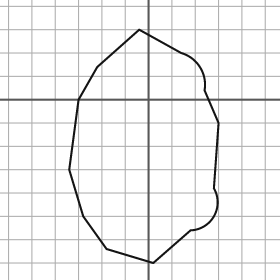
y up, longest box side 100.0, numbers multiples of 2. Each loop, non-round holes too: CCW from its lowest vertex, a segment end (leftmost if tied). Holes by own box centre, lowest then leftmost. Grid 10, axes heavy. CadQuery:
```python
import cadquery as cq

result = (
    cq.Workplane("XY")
    .moveTo(2.0, -70.0)
    .lineTo(18.0, -56.0)
    .threePointArc((28.0, -50.0), (28.0, -38.0))
    .lineTo(30.0, -10.0)
    .lineTo(24.0, 4.0)
    .threePointArc((22.0, 14.0), (14.0, 20.0))
    .lineTo(-4.0, 30.0)
    .lineTo(-22.0, 14.0)
    .lineTo(-30.0, 0.0)
    .lineTo(-34.0, -30.0)
    .lineTo(-28.0, -50.0)
    .lineTo(-18.0, -64.0)
    .close()
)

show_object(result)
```